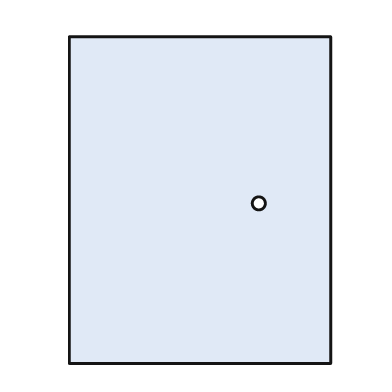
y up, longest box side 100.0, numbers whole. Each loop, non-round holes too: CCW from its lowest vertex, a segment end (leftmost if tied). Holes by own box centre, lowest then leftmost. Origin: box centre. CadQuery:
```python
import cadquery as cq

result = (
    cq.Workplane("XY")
    .moveTo(-40.0, -50.0)
    .lineTo(40.0, -50.0)
    .lineTo(40.0, 50.0)
    .lineTo(-40.0, 50.0)
    .close()
    .moveTo(18.0, -1.0)
    .circle(2.0)
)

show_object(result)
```